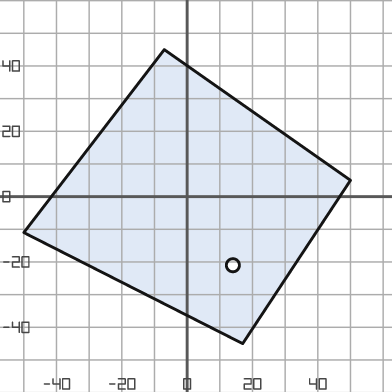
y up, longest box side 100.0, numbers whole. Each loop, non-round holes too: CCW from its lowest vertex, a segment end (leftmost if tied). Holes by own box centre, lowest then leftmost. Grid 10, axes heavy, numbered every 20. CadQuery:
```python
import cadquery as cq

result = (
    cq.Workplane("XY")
    .moveTo(17.0, -45.0)
    .lineTo(50.0, 5.0)
    .lineTo(-7.0, 45.0)
    .lineTo(-50.0, -11.0)
    .close()
    .moveTo(14.0, -21.0)
    .circle(2.0)
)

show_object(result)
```